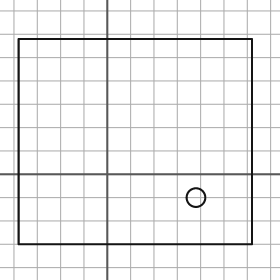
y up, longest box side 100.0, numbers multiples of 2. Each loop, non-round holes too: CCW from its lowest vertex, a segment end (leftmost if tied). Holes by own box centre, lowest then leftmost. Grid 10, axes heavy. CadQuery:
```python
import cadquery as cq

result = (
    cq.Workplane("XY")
    .moveTo(-38.0, -30.0)
    .lineTo(62.0, -30.0)
    .lineTo(62.0, 58.0)
    .lineTo(-38.0, 58.0)
    .close()
    .moveTo(38.0, -10.0)
    .circle(4.0)
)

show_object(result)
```